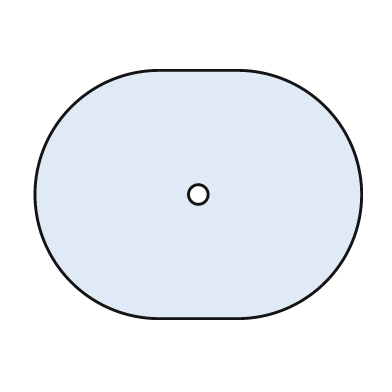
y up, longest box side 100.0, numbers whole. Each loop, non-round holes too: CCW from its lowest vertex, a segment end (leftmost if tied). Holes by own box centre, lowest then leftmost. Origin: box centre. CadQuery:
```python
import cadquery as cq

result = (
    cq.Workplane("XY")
    .moveTo(-12.0, -38.0)
    .lineTo(12.0, -38.0)
    .threePointArc((50.0, 0.0), (12.0, 38.0))
    .lineTo(-12.0, 38.0)
    .threePointArc((-50.0, 0.0), (-12.0, -38.0))
    .close()
    .moveTo(0.0, 0.0)
    .circle(3.0)
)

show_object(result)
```